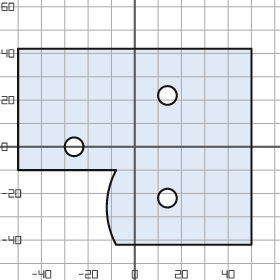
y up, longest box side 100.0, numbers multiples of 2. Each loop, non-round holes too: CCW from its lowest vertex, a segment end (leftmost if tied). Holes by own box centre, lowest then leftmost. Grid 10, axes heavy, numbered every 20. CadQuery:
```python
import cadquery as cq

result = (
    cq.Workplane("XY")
    .moveTo(-8.0, -42.0)
    .lineTo(50.0, -42.0)
    .lineTo(50.0, 42.0)
    .lineTo(-50.0, 42.0)
    .lineTo(-50.0, -10.0)
    .lineTo(-8.0, -10.0)
    .threePointArc((-12.0, -26.0), (-8.0, -42.0))
    .close()
    .moveTo(14.0, -22.0)
    .circle(4.0)
    .moveTo(-26.0, 0.0)
    .circle(4.0)
    .moveTo(14.0, 22.0)
    .circle(4.0)
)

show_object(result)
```